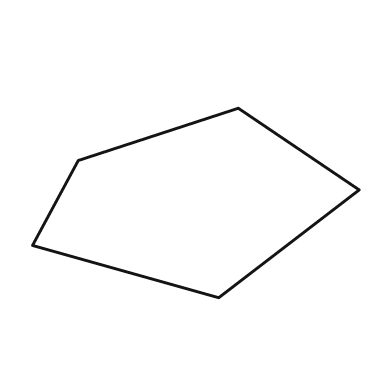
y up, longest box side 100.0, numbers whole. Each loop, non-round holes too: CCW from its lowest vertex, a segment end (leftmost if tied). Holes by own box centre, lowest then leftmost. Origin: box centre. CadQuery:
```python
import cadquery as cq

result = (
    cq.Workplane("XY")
    .moveTo(7.0, -29.0)
    .lineTo(50.0, 4.0)
    .lineTo(13.0, 29.0)
    .lineTo(-36.0, 13.0)
    .lineTo(-50.0, -13.0)
    .close()
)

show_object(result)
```